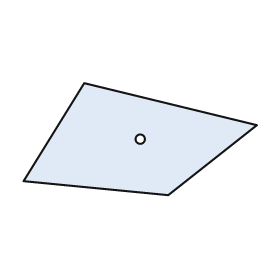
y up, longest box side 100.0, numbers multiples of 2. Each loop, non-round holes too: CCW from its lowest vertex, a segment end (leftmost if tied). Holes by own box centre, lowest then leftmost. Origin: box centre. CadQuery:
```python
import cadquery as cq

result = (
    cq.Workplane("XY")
    .moveTo(12.0, -24.0)
    .lineTo(50.0, 6.0)
    .lineTo(-24.0, 24.0)
    .lineTo(-50.0, -18.0)
    .close()
    .moveTo(0.0, 0.0)
    .circle(2.0)
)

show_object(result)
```